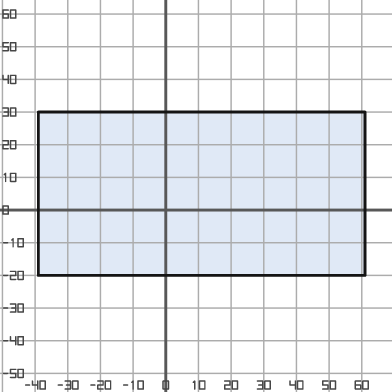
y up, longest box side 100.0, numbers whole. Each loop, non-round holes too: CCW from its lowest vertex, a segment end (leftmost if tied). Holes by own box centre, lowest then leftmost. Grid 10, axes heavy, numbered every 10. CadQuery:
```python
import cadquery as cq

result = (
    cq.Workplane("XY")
    .moveTo(-39.0, -20.0)
    .lineTo(61.0, -20.0)
    .lineTo(61.0, 30.0)
    .lineTo(-39.0, 30.0)
    .close()
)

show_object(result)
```